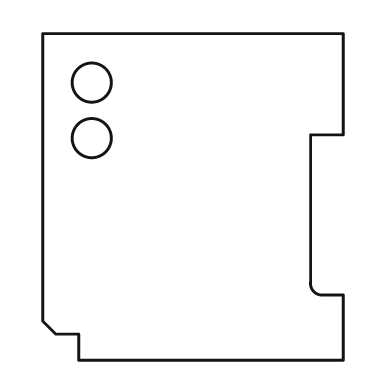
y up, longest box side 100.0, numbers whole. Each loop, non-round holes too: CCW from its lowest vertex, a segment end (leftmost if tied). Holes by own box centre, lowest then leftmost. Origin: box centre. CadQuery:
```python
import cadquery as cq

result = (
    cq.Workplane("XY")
    .moveTo(-35.0, -50.0)
    .lineTo(46.0, -50.0)
    .lineTo(46.0, -30.0)
    .lineTo(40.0, -30.0)
    .threePointArc((37.0, -29.0), (36.0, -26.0))
    .lineTo(36.0, 19.0)
    .lineTo(46.0, 19.0)
    .lineTo(46.0, 50.0)
    .lineTo(-46.0, 50.0)
    .lineTo(-46.0, -38.0)
    .lineTo(-42.0, -42.0)
    .lineTo(-35.0, -42.0)
    .close()
    .moveTo(-31.0, 18.0)
    .circle(6.0)
    .moveTo(-31.0, 35.0)
    .circle(6.0)
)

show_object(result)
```